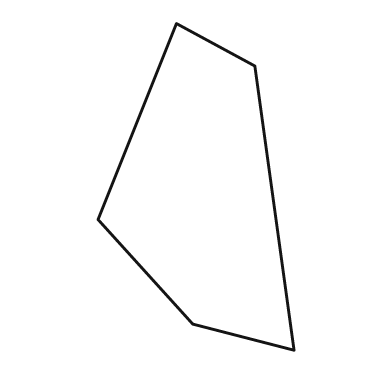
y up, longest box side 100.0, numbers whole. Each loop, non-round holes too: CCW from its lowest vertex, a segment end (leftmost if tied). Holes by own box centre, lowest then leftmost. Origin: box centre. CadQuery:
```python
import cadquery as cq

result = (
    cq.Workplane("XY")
    .moveTo(30.0, -50.0)
    .lineTo(18.0, 37.0)
    .lineTo(-6.0, 50.0)
    .lineTo(-30.0, -10.0)
    .lineTo(-1.0, -42.0)
    .close()
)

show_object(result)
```